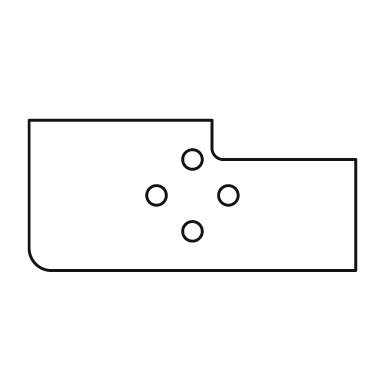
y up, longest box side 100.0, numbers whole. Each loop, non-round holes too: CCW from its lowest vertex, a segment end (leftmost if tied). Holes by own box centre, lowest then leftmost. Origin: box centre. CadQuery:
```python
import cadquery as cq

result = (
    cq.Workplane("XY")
    .moveTo(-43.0, -23.0)
    .lineTo(50.0, -23.0)
    .lineTo(50.0, 11.0)
    .lineTo(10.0, 11.0)
    .threePointArc((7.0, 12.0), (6.0, 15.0))
    .lineTo(6.0, 23.0)
    .lineTo(-50.0, 23.0)
    .lineTo(-50.0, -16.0)
    .threePointArc((-48.0, -21.0), (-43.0, -23.0))
    .close()
    .moveTo(0.0, -11.0)
    .circle(3.0)
    .moveTo(-11.0, 0.0)
    .circle(3.0)
    .moveTo(11.0, 0.0)
    .circle(3.0)
    .moveTo(0.0, 11.0)
    .circle(3.0)
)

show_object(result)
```